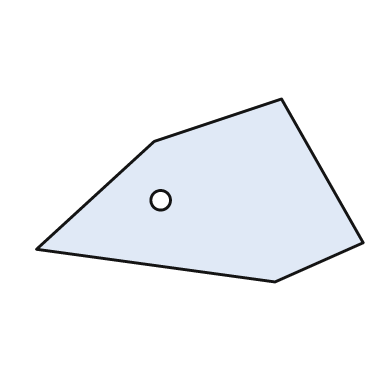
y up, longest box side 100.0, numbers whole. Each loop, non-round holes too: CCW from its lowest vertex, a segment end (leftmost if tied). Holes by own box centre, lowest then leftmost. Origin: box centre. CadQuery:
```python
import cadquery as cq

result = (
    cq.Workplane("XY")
    .moveTo(23.0, -28.0)
    .lineTo(50.0, -16.0)
    .lineTo(25.0, 28.0)
    .lineTo(-14.0, 15.0)
    .lineTo(-50.0, -18.0)
    .close()
    .moveTo(-12.0, -3.0)
    .circle(3.0)
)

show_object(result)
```